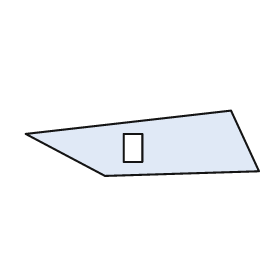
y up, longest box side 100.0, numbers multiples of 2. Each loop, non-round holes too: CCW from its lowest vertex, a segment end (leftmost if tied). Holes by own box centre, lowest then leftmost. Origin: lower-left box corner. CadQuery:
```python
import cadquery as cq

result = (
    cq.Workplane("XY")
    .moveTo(34.0, 0.0)
    .lineTo(100.0, 2.0)
    .lineTo(88.0, 28.0)
    .lineTo(0.0, 18.0)
    .close()
    .moveTo(42.0, 6.0)
    .lineTo(50.0, 6.0)
    .lineTo(50.0, 18.0)
    .lineTo(42.0, 18.0)
    .close()
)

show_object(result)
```